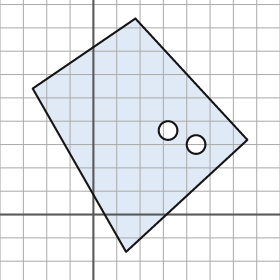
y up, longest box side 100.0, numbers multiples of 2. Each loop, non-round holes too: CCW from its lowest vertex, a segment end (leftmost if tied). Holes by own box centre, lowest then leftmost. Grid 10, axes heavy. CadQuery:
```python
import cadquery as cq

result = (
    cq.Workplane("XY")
    .moveTo(14.0, -16.0)
    .lineTo(66.0, 32.0)
    .lineTo(18.0, 84.0)
    .lineTo(-26.0, 54.0)
    .close()
    .moveTo(44.0, 30.0)
    .circle(4.0)
    .moveTo(32.0, 36.0)
    .circle(4.0)
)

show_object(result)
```